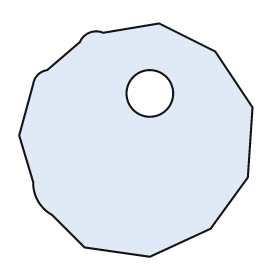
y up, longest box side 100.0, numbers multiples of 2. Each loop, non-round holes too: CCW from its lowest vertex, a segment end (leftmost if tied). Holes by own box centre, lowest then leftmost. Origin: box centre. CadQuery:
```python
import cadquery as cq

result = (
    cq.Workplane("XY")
    .moveTo(6.0, -50.0)
    .lineTo(32.0, -38.0)
    .lineTo(48.0, -16.0)
    .lineTo(50.0, 14.0)
    .lineTo(34.0, 38.0)
    .lineTo(10.0, 50.0)
    .lineTo(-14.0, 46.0)
    .threePointArc((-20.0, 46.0), (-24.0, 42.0))
    .lineTo(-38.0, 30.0)
    .threePointArc((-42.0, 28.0), (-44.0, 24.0))
    .lineTo(-50.0, 2.0)
    .lineTo(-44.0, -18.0)
    .threePointArc((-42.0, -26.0), (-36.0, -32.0))
    .lineTo(-22.0, -46.0)
    .close()
    .moveTo(6.0, 20.0)
    .circle(10.0)
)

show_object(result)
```